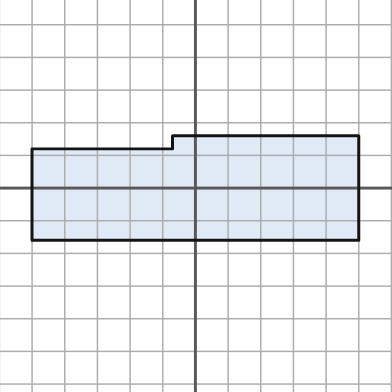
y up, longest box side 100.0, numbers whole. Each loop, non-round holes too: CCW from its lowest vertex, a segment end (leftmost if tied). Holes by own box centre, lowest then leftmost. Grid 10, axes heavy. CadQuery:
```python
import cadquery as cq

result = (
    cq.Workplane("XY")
    .moveTo(-50.0, -16.0)
    .lineTo(50.0, -16.0)
    .lineTo(50.0, 16.0)
    .lineTo(-7.0, 16.0)
    .lineTo(-7.0, 12.0)
    .lineTo(-50.0, 12.0)
    .close()
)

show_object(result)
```